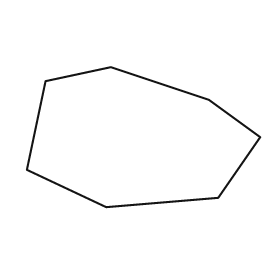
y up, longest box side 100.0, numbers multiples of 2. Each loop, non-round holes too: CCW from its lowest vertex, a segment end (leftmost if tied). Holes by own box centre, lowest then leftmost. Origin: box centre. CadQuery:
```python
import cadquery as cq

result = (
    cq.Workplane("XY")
    .moveTo(-16.0, -30.0)
    .lineTo(32.0, -26.0)
    .lineTo(50.0, 0.0)
    .lineTo(28.0, 16.0)
    .lineTo(-14.0, 30.0)
    .lineTo(-42.0, 24.0)
    .lineTo(-50.0, -14.0)
    .close()
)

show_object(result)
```